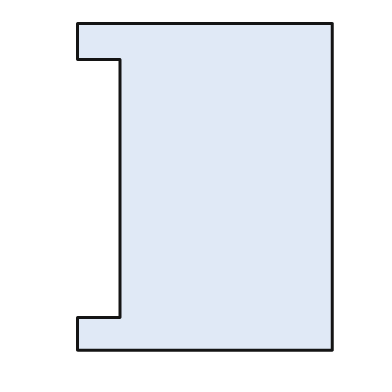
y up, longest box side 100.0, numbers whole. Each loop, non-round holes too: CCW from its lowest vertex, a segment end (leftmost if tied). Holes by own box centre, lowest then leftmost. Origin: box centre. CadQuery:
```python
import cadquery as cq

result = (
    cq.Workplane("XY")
    .moveTo(-39.0, -50.0)
    .lineTo(39.0, -50.0)
    .lineTo(39.0, 50.0)
    .lineTo(-39.0, 50.0)
    .lineTo(-39.0, 39.0)
    .lineTo(-26.0, 39.0)
    .lineTo(-26.0, -40.0)
    .lineTo(-39.0, -40.0)
    .close()
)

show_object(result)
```